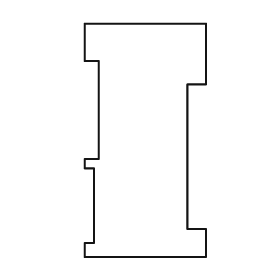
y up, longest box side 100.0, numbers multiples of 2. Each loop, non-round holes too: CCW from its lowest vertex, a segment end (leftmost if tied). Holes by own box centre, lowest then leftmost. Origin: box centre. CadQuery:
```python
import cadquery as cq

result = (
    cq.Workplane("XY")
    .moveTo(-26.0, -50.0)
    .lineTo(26.0, -50.0)
    .lineTo(26.0, -38.0)
    .lineTo(18.0, -38.0)
    .lineTo(18.0, 24.0)
    .lineTo(26.0, 24.0)
    .lineTo(26.0, 50.0)
    .lineTo(-26.0, 50.0)
    .lineTo(-26.0, 34.0)
    .lineTo(-20.0, 34.0)
    .lineTo(-20.0, -8.0)
    .lineTo(-26.0, -8.0)
    .lineTo(-26.0, -12.0)
    .lineTo(-22.0, -12.0)
    .lineTo(-22.0, -44.0)
    .lineTo(-26.0, -44.0)
    .close()
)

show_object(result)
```